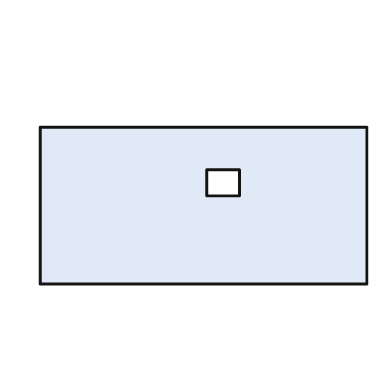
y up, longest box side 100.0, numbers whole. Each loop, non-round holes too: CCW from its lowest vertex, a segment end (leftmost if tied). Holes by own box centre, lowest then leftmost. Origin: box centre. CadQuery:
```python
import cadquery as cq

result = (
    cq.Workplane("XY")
    .moveTo(-50.0, -24.0)
    .lineTo(50.0, -24.0)
    .lineTo(50.0, 24.0)
    .lineTo(-50.0, 24.0)
    .close()
    .moveTo(1.0, 3.0)
    .lineTo(11.0, 3.0)
    .lineTo(11.0, 11.0)
    .lineTo(1.0, 11.0)
    .close()
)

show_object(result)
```